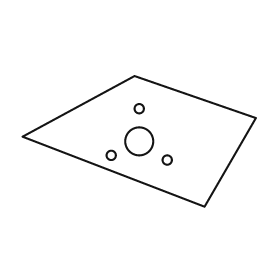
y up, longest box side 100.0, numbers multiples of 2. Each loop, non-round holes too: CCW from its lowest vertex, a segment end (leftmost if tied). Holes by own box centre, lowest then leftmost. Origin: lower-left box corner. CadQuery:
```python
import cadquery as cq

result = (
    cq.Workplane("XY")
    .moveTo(78.0, 0.0)
    .lineTo(100.0, 38.0)
    .lineTo(48.0, 56.0)
    .lineTo(0.0, 30.0)
    .close()
    .moveTo(62.0, 20.0)
    .circle(2.0)
    .moveTo(38.0, 22.0)
    .circle(2.0)
    .moveTo(50.0, 28.0)
    .circle(6.0)
    .moveTo(50.0, 42.0)
    .circle(2.0)
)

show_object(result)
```